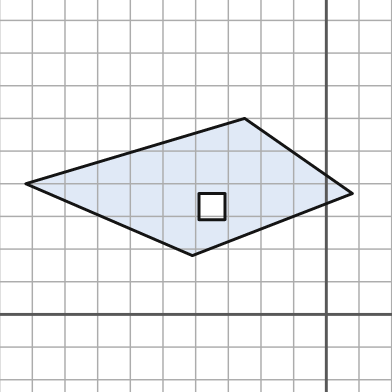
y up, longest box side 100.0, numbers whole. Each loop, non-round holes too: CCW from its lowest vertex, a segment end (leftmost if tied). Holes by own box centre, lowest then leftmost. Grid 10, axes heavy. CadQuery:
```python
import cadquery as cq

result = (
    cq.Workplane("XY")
    .moveTo(-41.0, 18.0)
    .lineTo(8.0, 37.0)
    .lineTo(-25.0, 60.0)
    .lineTo(-92.0, 40.0)
    .close()
    .moveTo(-39.0, 29.0)
    .lineTo(-31.0, 29.0)
    .lineTo(-31.0, 37.0)
    .lineTo(-39.0, 37.0)
    .close()
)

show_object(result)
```